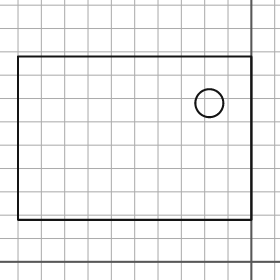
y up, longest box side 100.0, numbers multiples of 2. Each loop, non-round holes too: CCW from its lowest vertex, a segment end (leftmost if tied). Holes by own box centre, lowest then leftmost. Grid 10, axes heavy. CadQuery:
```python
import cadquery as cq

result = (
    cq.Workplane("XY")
    .moveTo(-100.0, 18.0)
    .lineTo(0.0, 18.0)
    .lineTo(0.0, 88.0)
    .lineTo(-100.0, 88.0)
    .close()
    .moveTo(-18.0, 68.0)
    .circle(6.0)
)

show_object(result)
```